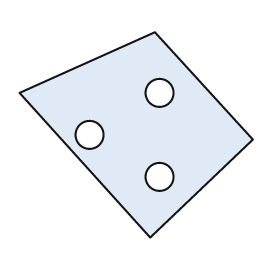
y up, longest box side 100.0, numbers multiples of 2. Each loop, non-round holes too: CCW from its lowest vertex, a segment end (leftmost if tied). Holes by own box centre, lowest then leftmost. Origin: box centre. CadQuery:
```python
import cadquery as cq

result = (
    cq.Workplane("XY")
    .moveTo(6.0, -44.0)
    .lineTo(50.0, -2.0)
    .lineTo(8.0, 44.0)
    .lineTo(-50.0, 18.0)
    .close()
    .moveTo(10.0, -18.0)
    .circle(6.0)
    .moveTo(-20.0, 0.0)
    .circle(6.0)
    .moveTo(10.0, 18.0)
    .circle(6.0)
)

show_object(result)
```